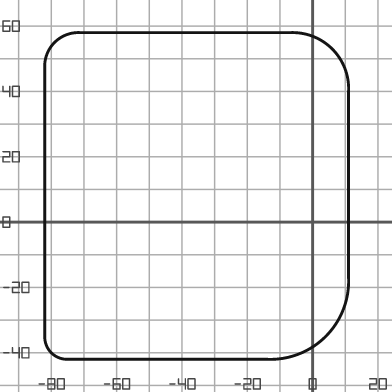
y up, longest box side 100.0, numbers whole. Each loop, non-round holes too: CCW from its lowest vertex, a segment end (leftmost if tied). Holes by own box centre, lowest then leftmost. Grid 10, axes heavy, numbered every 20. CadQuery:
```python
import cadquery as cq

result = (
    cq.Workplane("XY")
    .moveTo(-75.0, -42.0)
    .lineTo(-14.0, -42.0)
    .threePointArc((4.0, -35.0), (11.0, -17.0))
    .lineTo(11.0, 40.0)
    .threePointArc((6.0, 53.0), (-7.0, 58.0))
    .lineTo(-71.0, 58.0)
    .threePointArc((-79.0, 55.0), (-82.0, 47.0))
    .lineTo(-82.0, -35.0)
    .threePointArc((-80.0, -40.0), (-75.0, -42.0))
    .close()
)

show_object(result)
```